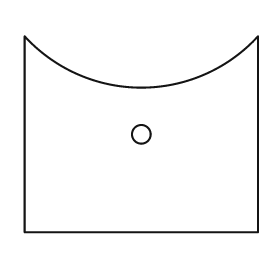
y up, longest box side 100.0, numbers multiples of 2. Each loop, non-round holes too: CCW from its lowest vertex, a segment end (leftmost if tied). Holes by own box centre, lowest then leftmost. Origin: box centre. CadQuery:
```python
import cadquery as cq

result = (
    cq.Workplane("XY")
    .moveTo(-50.0, -42.0)
    .lineTo(50.0, -42.0)
    .lineTo(50.0, 42.0)
    .threePointArc((0.0, 20.0), (-50.0, 42.0))
    .close()
    .moveTo(0.0, 0.0)
    .circle(4.0)
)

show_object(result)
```